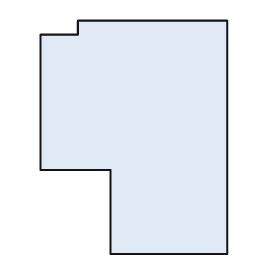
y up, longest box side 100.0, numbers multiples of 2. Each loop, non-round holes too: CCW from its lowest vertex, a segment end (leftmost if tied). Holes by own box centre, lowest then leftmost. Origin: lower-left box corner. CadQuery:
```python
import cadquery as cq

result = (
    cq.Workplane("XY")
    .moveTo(30.0, 0.0)
    .lineTo(80.0, 0.0)
    .lineTo(80.0, 100.0)
    .lineTo(16.0, 100.0)
    .lineTo(16.0, 94.0)
    .lineTo(0.0, 94.0)
    .lineTo(0.0, 36.0)
    .lineTo(30.0, 36.0)
    .close()
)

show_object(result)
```